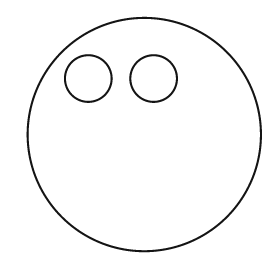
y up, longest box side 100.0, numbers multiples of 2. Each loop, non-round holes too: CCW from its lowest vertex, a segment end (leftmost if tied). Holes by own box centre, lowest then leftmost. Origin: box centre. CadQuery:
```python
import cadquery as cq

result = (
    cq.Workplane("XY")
    .moveTo(0.0, 0.0)
    .circle(50.0)
    .moveTo(-24.0, 24.0)
    .circle(10.0)
    .moveTo(4.0, 24.0)
    .circle(10.0)
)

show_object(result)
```